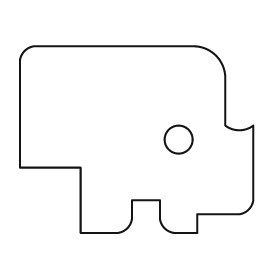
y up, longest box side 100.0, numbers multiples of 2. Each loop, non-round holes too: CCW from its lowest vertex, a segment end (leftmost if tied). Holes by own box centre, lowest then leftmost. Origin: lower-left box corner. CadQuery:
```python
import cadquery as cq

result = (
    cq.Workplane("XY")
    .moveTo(26.0, 0.0)
    .lineTo(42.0, 0.0)
    .threePointArc((46.0, 2.0), (48.0, 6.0))
    .lineTo(48.0, 14.0)
    .lineTo(60.0, 14.0)
    .lineTo(60.0, 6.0)
    .threePointArc((62.0, 2.0), (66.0, 0.0))
    .lineTo(76.0, 0.0)
    .lineTo(76.0, 8.0)
    .lineTo(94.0, 8.0)
    .threePointArc((98.0, 10.0), (100.0, 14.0))
    .lineTo(100.0, 46.0)
    .threePointArc((94.0, 44.0), (88.0, 46.0))
    .lineTo(88.0, 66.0)
    .threePointArc((84.0, 76.0), (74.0, 80.0))
    .lineTo(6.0, 80.0)
    .threePointArc((2.0, 78.0), (0.0, 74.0))
    .lineTo(0.0, 28.0)
    .lineTo(26.0, 28.0)
    .close()
    .moveTo(68.0, 40.0)
    .circle(6.0)
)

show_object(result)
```